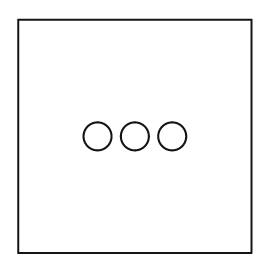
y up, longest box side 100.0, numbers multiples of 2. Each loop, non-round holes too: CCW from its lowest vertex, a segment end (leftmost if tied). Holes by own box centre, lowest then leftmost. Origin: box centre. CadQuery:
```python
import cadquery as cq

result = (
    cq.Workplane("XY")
    .moveTo(-50.0, -50.0)
    .lineTo(50.0, -50.0)
    .lineTo(50.0, 50.0)
    .lineTo(-50.0, 50.0)
    .close()
    .moveTo(-16.0, 0.0)
    .circle(6.0)
    .moveTo(0.0, 0.0)
    .circle(6.0)
    .moveTo(16.0, 0.0)
    .circle(6.0)
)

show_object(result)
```